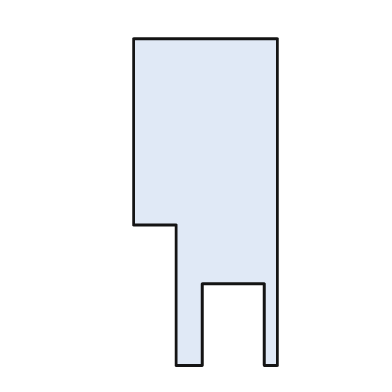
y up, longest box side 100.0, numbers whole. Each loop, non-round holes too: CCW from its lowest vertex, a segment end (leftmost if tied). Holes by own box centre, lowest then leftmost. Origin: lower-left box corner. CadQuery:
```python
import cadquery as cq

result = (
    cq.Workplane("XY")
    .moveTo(13.0, 0.0)
    .lineTo(21.0, 0.0)
    .lineTo(21.0, 25.0)
    .lineTo(40.0, 25.0)
    .lineTo(40.0, 0.0)
    .lineTo(44.0, 0.0)
    .lineTo(44.0, 100.0)
    .lineTo(0.0, 100.0)
    .lineTo(0.0, 43.0)
    .lineTo(13.0, 43.0)
    .close()
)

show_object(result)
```